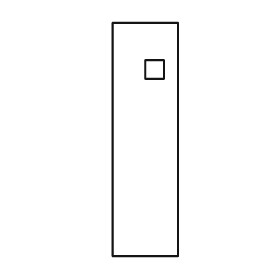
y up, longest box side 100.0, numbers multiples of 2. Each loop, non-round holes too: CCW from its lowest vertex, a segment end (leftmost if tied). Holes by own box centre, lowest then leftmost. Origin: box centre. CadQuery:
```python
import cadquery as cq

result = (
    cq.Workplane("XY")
    .moveTo(-14.0, -50.0)
    .lineTo(14.0, -50.0)
    .lineTo(14.0, 50.0)
    .lineTo(-14.0, 50.0)
    .close()
    .moveTo(0.0, 26.0)
    .lineTo(8.0, 26.0)
    .lineTo(8.0, 34.0)
    .lineTo(0.0, 34.0)
    .close()
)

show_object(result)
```